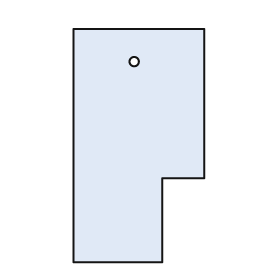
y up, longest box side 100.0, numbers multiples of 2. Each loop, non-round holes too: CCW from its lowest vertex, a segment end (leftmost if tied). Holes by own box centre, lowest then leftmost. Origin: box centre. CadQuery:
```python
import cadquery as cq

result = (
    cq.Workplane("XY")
    .moveTo(-28.0, -50.0)
    .lineTo(10.0, -50.0)
    .lineTo(10.0, -14.0)
    .lineTo(28.0, -14.0)
    .lineTo(28.0, 50.0)
    .lineTo(-28.0, 50.0)
    .close()
    .moveTo(-2.0, 36.0)
    .circle(2.0)
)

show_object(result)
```